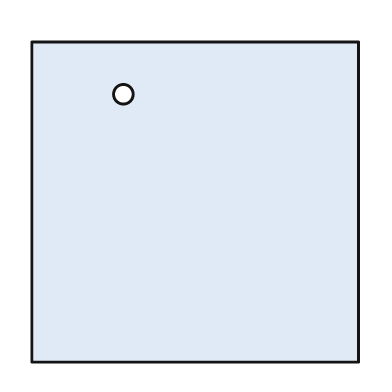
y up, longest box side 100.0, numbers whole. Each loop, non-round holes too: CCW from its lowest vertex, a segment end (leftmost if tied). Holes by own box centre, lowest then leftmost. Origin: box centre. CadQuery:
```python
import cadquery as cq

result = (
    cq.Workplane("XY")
    .moveTo(-50.0, -49.0)
    .lineTo(50.0, -49.0)
    .lineTo(50.0, 49.0)
    .lineTo(-50.0, 49.0)
    .close()
    .moveTo(-22.0, 33.0)
    .circle(3.0)
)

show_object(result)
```